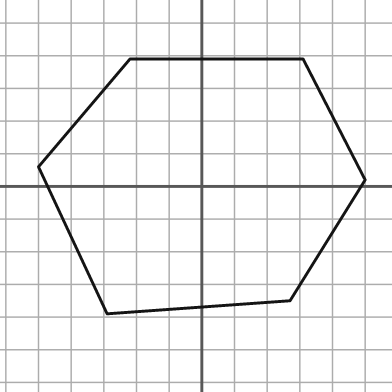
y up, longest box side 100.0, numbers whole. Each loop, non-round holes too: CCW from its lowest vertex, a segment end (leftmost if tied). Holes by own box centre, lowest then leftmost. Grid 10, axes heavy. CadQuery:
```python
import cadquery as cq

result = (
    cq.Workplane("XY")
    .moveTo(-29.0, -39.0)
    .lineTo(27.0, -35.0)
    .lineTo(50.0, 2.0)
    .lineTo(31.0, 39.0)
    .lineTo(-22.0, 39.0)
    .lineTo(-50.0, 6.0)
    .close()
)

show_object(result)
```